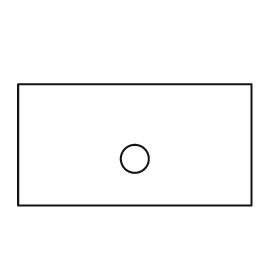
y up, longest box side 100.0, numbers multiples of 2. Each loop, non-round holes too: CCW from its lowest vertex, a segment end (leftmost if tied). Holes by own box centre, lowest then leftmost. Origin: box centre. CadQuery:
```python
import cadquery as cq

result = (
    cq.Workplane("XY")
    .moveTo(-50.0, -26.0)
    .lineTo(50.0, -26.0)
    .lineTo(50.0, 26.0)
    .lineTo(-50.0, 26.0)
    .close()
    .moveTo(0.0, -6.0)
    .circle(6.0)
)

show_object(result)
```